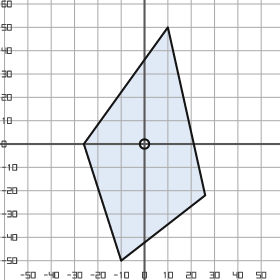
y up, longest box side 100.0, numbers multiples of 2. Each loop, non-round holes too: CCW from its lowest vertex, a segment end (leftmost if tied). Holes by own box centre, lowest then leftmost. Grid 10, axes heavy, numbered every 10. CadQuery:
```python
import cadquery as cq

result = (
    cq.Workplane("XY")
    .moveTo(-10.0, -50.0)
    .lineTo(26.0, -22.0)
    .lineTo(10.0, 50.0)
    .lineTo(-26.0, 0.0)
    .close()
    .moveTo(0.0, 0.0)
    .circle(2.0)
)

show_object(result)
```